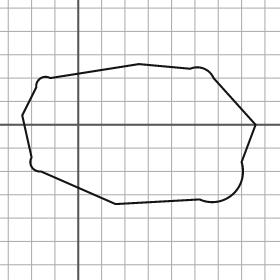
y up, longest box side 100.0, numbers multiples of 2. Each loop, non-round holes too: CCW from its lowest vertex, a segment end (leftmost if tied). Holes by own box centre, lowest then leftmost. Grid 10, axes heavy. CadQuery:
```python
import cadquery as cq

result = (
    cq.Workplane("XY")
    .moveTo(16.0, -34.0)
    .lineTo(52.0, -32.0)
    .threePointArc((66.0, -30.0), (70.0, -16.0))
    .lineTo(76.0, 0.0)
    .lineTo(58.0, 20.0)
    .threePointArc((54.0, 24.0), (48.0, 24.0))
    .lineTo(26.0, 26.0)
    .lineTo(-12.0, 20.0)
    .threePointArc((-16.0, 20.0), (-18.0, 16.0))
    .lineTo(-24.0, 4.0)
    .lineTo(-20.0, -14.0)
    .threePointArc((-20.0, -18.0), (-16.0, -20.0))
    .close()
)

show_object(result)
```